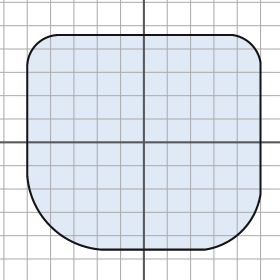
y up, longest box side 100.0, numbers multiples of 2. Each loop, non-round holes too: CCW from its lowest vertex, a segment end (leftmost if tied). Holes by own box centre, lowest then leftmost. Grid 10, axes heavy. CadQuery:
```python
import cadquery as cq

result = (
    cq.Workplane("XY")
    .moveTo(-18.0, -46.0)
    .lineTo(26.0, -46.0)
    .threePointArc((42.0, -38.0), (50.0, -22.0))
    .lineTo(50.0, 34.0)
    .threePointArc((46.0, 42.0), (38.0, 46.0))
    .lineTo(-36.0, 46.0)
    .threePointArc((-46.0, 42.0), (-50.0, 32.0))
    .lineTo(-50.0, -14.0)
    .threePointArc((-40.0, -36.0), (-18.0, -46.0))
    .close()
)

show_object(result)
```